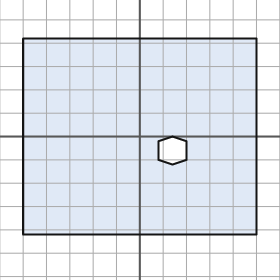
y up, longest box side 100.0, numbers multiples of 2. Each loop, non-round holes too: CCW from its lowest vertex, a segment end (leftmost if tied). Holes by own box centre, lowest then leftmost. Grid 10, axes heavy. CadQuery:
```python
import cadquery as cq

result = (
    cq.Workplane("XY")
    .moveTo(-50.0, -42.0)
    .lineTo(50.0, -42.0)
    .lineTo(50.0, 42.0)
    .lineTo(-50.0, 42.0)
    .close()
    .moveTo(14.0, -12.0)
    .lineTo(20.0, -10.0)
    .lineTo(20.0, -2.0)
    .lineTo(14.0, 0.0)
    .lineTo(8.0, -2.0)
    .lineTo(8.0, -10.0)
    .close()
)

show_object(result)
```